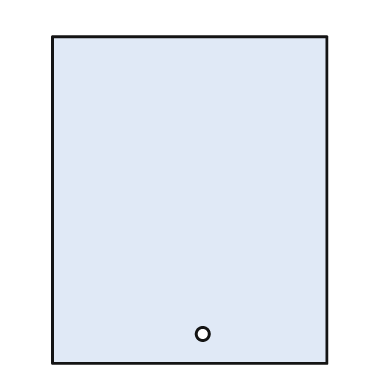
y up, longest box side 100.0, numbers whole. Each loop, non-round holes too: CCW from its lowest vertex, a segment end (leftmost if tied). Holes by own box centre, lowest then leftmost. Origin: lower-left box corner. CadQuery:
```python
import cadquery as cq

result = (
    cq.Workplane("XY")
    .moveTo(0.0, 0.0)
    .lineTo(84.0, 0.0)
    .lineTo(84.0, 100.0)
    .lineTo(0.0, 100.0)
    .close()
    .moveTo(46.0, 9.0)
    .circle(2.0)
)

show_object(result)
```